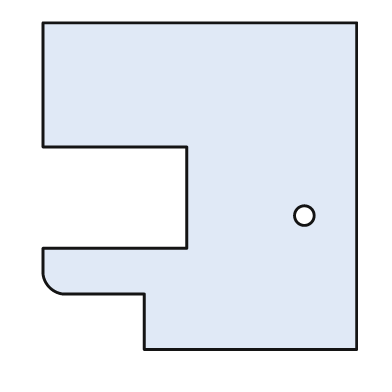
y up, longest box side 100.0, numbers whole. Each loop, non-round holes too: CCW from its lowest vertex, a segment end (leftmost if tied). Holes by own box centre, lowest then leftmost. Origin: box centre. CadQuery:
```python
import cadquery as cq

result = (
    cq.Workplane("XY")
    .moveTo(-17.0, -50.0)
    .lineTo(48.0, -50.0)
    .lineTo(48.0, 50.0)
    .lineTo(-48.0, 50.0)
    .lineTo(-48.0, 12.0)
    .lineTo(-4.0, 12.0)
    .lineTo(-4.0, -19.0)
    .lineTo(-48.0, -19.0)
    .lineTo(-48.0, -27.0)
    .threePointArc((-46.0, -31.0), (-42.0, -33.0))
    .lineTo(-17.0, -33.0)
    .close()
    .moveTo(32.0, -9.0)
    .circle(3.0)
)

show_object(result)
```